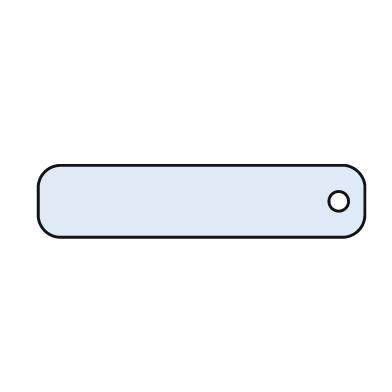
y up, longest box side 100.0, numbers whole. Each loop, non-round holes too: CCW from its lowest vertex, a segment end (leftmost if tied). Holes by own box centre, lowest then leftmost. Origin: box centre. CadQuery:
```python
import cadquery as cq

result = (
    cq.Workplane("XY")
    .moveTo(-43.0, -11.0)
    .lineTo(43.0, -11.0)
    .threePointArc((48.0, -9.0), (50.0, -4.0))
    .lineTo(50.0, 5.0)
    .threePointArc((48.0, 9.0), (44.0, 11.0))
    .lineTo(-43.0, 11.0)
    .threePointArc((-48.0, 9.0), (-50.0, 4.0))
    .lineTo(-50.0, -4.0)
    .threePointArc((-48.0, -9.0), (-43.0, -11.0))
    .close()
    .moveTo(42.0, 0.0)
    .circle(3.0)
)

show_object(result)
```